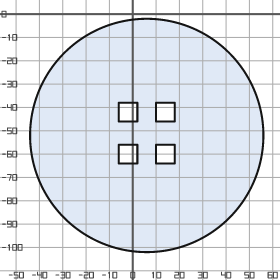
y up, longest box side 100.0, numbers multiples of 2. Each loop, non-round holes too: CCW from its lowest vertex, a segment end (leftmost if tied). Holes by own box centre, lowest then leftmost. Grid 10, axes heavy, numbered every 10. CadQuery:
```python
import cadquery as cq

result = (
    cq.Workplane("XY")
    .moveTo(6.0, -52.0)
    .circle(50.0)
    .moveTo(-6.0, -64.0)
    .lineTo(2.0, -64.0)
    .lineTo(2.0, -56.0)
    .lineTo(-6.0, -56.0)
    .close()
    .moveTo(10.0, -64.0)
    .lineTo(18.0, -64.0)
    .lineTo(18.0, -56.0)
    .lineTo(10.0, -56.0)
    .close()
    .moveTo(-6.0, -46.0)
    .lineTo(2.0, -46.0)
    .lineTo(2.0, -38.0)
    .lineTo(-6.0, -38.0)
    .close()
    .moveTo(10.0, -46.0)
    .lineTo(18.0, -46.0)
    .lineTo(18.0, -38.0)
    .lineTo(10.0, -38.0)
    .close()
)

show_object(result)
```